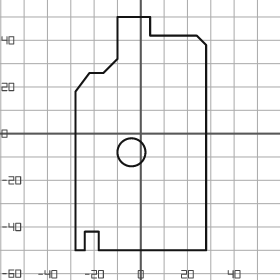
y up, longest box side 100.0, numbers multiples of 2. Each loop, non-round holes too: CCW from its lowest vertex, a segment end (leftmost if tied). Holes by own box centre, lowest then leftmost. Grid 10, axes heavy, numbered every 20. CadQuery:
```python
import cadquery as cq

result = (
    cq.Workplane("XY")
    .moveTo(-28.0, -50.0)
    .lineTo(-24.0, -50.0)
    .lineTo(-24.0, -42.0)
    .lineTo(-18.0, -42.0)
    .lineTo(-18.0, -50.0)
    .lineTo(28.0, -50.0)
    .lineTo(28.0, 38.0)
    .lineTo(24.0, 42.0)
    .lineTo(4.0, 42.0)
    .lineTo(4.0, 50.0)
    .lineTo(-10.0, 50.0)
    .lineTo(-10.0, 32.0)
    .lineTo(-16.0, 26.0)
    .lineTo(-22.0, 26.0)
    .lineTo(-28.0, 18.0)
    .close()
    .moveTo(-4.0, -8.0)
    .circle(6.0)
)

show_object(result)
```